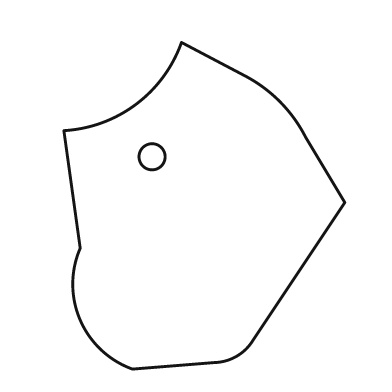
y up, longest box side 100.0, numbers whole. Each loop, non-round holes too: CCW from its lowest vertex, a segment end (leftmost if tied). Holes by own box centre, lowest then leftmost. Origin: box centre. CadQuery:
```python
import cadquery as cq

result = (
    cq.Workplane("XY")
    .moveTo(-22.0, -50.0)
    .lineTo(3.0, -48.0)
    .threePointArc((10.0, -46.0), (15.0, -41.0))
    .lineTo(43.0, 1.0)
    .lineTo(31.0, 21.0)
    .threePointArc((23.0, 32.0), (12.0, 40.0))
    .lineTo(-7.0, 50.0)
    .threePointArc((-21.0, 31.0), (-43.0, 23.0))
    .lineTo(-38.0, -13.0)
    .threePointArc((-38.0, -35.0), (-22.0, -50.0))
    .close()
    .moveTo(-16.0, 15.0)
    .circle(4.0)
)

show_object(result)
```